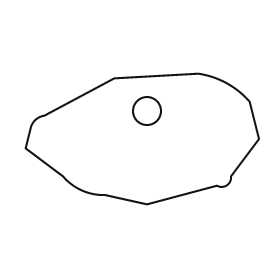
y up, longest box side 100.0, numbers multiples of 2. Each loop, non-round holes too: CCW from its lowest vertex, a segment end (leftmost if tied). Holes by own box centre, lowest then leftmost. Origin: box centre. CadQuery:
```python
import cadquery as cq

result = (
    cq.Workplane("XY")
    .moveTo(2.0, -28.0)
    .lineTo(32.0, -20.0)
    .threePointArc((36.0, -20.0), (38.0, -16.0))
    .lineTo(50.0, 0.0)
    .lineTo(46.0, 16.0)
    .threePointArc((36.0, 24.0), (24.0, 28.0))
    .lineTo(-12.0, 26.0)
    .lineTo(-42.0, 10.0)
    .threePointArc((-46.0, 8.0), (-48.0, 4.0))
    .lineTo(-50.0, -4.0)
    .lineTo(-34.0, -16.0)
    .threePointArc((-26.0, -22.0), (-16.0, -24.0))
    .close()
    .moveTo(2.0, 12.0)
    .circle(6.0)
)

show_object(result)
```